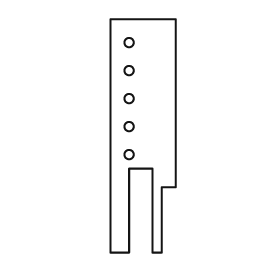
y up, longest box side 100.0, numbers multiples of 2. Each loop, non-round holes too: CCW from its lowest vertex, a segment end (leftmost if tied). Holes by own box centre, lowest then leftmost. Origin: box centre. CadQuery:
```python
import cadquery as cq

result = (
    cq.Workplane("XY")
    .moveTo(-14.0, -50.0)
    .lineTo(-6.0, -50.0)
    .lineTo(-6.0, -14.0)
    .lineTo(4.0, -14.0)
    .lineTo(4.0, -50.0)
    .lineTo(8.0, -50.0)
    .lineTo(8.0, -22.0)
    .lineTo(14.0, -22.0)
    .lineTo(14.0, 50.0)
    .lineTo(-14.0, 50.0)
    .close()
    .moveTo(-6.0, -8.0)
    .circle(2.0)
    .moveTo(-6.0, 4.0)
    .circle(2.0)
    .moveTo(-6.0, 16.0)
    .circle(2.0)
    .moveTo(-6.0, 28.0)
    .circle(2.0)
    .moveTo(-6.0, 40.0)
    .circle(2.0)
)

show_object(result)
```